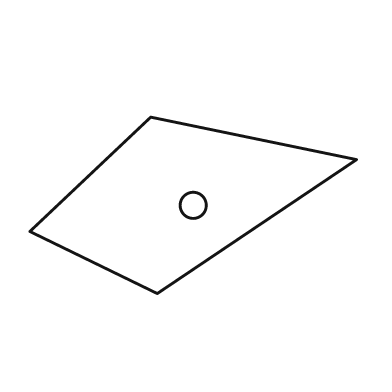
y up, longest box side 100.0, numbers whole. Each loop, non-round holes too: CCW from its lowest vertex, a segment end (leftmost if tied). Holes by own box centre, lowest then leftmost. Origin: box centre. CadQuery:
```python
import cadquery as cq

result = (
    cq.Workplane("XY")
    .moveTo(-11.0, -27.0)
    .lineTo(50.0, 14.0)
    .lineTo(-13.0, 27.0)
    .lineTo(-50.0, -8.0)
    .close()
    .moveTo(0.0, 0.0)
    .circle(4.0)
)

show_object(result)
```